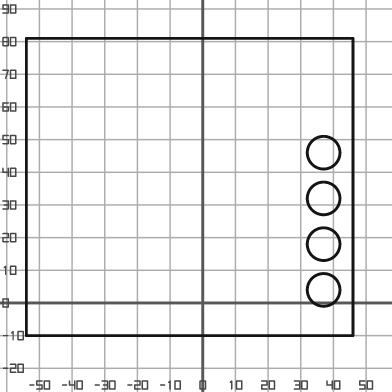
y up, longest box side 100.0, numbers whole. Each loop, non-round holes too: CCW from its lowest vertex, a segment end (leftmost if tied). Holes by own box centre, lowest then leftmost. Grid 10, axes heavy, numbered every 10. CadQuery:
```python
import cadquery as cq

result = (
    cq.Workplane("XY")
    .moveTo(-54.0, -10.0)
    .lineTo(46.0, -10.0)
    .lineTo(46.0, 81.0)
    .lineTo(-54.0, 81.0)
    .close()
    .moveTo(37.0, 4.0)
    .circle(5.0)
    .moveTo(37.0, 18.0)
    .circle(5.0)
    .moveTo(37.0, 32.0)
    .circle(5.0)
    .moveTo(37.0, 46.0)
    .circle(5.0)
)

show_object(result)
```